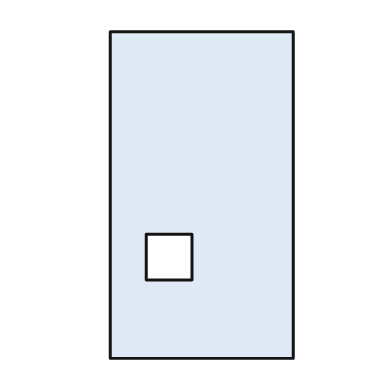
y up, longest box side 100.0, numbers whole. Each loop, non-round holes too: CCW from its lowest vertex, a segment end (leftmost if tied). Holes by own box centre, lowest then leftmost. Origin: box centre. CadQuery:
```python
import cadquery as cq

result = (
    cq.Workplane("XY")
    .moveTo(-28.0, -50.0)
    .lineTo(28.0, -50.0)
    .lineTo(28.0, 50.0)
    .lineTo(-28.0, 50.0)
    .close()
    .moveTo(-17.0, -26.0)
    .lineTo(-3.0, -26.0)
    .lineTo(-3.0, -12.0)
    .lineTo(-17.0, -12.0)
    .close()
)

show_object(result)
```